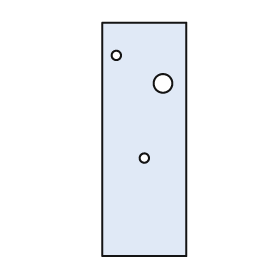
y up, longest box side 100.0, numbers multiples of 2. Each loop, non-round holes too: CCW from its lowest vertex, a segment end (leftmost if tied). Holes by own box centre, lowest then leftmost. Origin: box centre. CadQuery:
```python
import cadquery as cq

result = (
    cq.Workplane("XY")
    .moveTo(-18.0, -50.0)
    .lineTo(18.0, -50.0)
    .lineTo(18.0, 50.0)
    .lineTo(-18.0, 50.0)
    .close()
    .moveTo(0.0, -8.0)
    .circle(2.0)
    .moveTo(8.0, 24.0)
    .circle(4.0)
    .moveTo(-12.0, 36.0)
    .circle(2.0)
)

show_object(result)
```